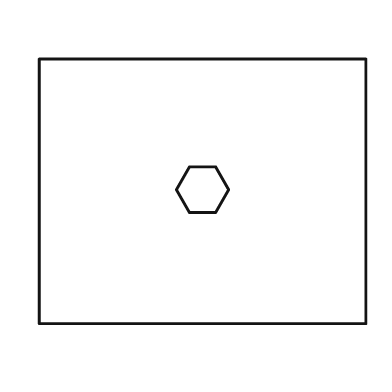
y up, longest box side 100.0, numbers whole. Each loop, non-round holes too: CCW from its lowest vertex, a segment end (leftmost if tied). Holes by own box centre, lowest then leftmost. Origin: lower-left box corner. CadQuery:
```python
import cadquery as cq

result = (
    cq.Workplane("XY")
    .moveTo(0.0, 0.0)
    .lineTo(100.0, 0.0)
    .lineTo(100.0, 81.0)
    .lineTo(0.0, 81.0)
    .close()
    .moveTo(46.0, 34.0)
    .lineTo(54.0, 34.0)
    .lineTo(58.0, 41.0)
    .lineTo(54.0, 48.0)
    .lineTo(46.0, 48.0)
    .lineTo(42.0, 41.0)
    .close()
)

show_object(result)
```